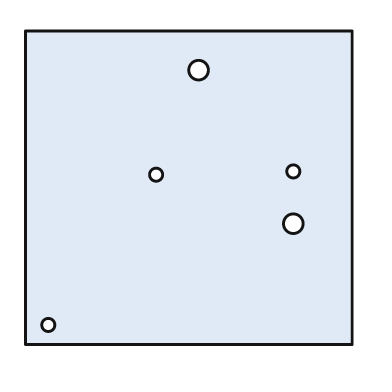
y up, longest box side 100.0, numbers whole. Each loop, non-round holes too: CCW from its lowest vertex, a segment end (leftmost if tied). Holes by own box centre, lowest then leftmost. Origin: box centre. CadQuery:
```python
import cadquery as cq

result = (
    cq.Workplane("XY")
    .moveTo(-50.0, -48.0)
    .lineTo(50.0, -48.0)
    .lineTo(50.0, 48.0)
    .lineTo(-50.0, 48.0)
    .close()
    .moveTo(-43.0, -42.0)
    .circle(2.0)
    .moveTo(32.0, -11.0)
    .circle(3.0)
    .moveTo(-10.0, 4.0)
    .circle(2.0)
    .moveTo(32.0, 5.0)
    .circle(2.0)
    .moveTo(3.0, 36.0)
    .circle(3.0)
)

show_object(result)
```